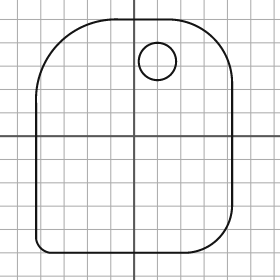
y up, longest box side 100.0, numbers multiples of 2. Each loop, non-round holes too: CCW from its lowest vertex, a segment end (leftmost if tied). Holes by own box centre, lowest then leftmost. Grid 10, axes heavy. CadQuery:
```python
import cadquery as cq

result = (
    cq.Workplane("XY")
    .moveTo(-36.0, -50.0)
    .lineTo(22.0, -50.0)
    .threePointArc((36.0, -44.0), (42.0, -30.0))
    .lineTo(42.0, 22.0)
    .threePointArc((34.0, 42.0), (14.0, 50.0))
    .lineTo(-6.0, 50.0)
    .threePointArc((-32.0, 40.0), (-42.0, 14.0))
    .lineTo(-42.0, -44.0)
    .threePointArc((-40.0, -48.0), (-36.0, -50.0))
    .close()
    .moveTo(10.0, 32.0)
    .circle(8.0)
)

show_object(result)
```